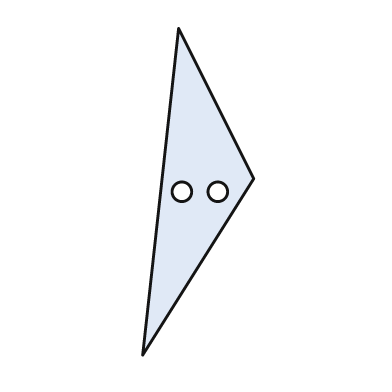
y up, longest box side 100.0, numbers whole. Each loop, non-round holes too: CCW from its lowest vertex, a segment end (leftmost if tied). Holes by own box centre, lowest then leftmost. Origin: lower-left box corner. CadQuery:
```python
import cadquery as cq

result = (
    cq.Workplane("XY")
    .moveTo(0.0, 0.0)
    .lineTo(34.0, 54.0)
    .lineTo(11.0, 100.0)
    .close()
    .moveTo(12.0, 50.0)
    .circle(3.0)
    .moveTo(23.0, 50.0)
    .circle(3.0)
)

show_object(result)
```